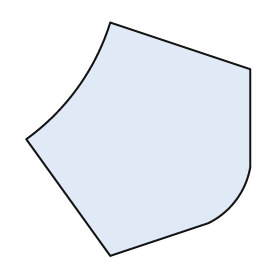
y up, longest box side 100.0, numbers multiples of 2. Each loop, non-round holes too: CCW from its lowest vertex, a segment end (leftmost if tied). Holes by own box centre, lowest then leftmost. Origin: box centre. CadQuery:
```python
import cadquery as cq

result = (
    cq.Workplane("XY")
    .moveTo(-12.0, -50.0)
    .lineTo(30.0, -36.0)
    .threePointArc((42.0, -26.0), (48.0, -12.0))
    .lineTo(48.0, 30.0)
    .lineTo(-12.0, 50.0)
    .threePointArc((-26.0, 22.0), (-48.0, 0.0))
    .close()
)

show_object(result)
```